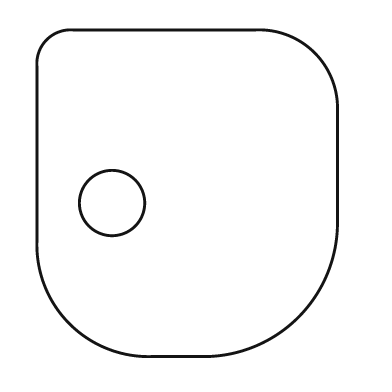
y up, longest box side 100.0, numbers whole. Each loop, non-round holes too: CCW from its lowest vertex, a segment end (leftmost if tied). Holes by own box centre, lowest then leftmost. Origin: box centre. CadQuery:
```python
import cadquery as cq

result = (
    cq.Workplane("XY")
    .moveTo(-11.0, -50.0)
    .lineTo(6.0, -50.0)
    .threePointArc((34.0, -38.0), (46.0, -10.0))
    .lineTo(46.0, 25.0)
    .threePointArc((39.0, 43.0), (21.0, 50.0))
    .lineTo(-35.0, 50.0)
    .threePointArc((-43.0, 47.0), (-46.0, 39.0))
    .lineTo(-46.0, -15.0)
    .threePointArc((-36.0, -40.0), (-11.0, -50.0))
    .close()
    .moveTo(-23.0, -3.0)
    .circle(10.0)
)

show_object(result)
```